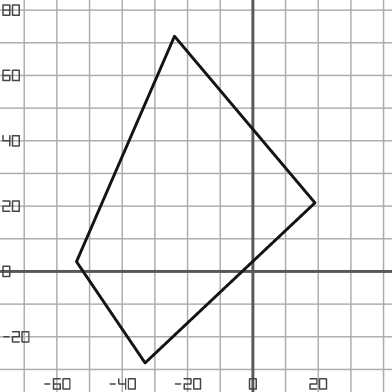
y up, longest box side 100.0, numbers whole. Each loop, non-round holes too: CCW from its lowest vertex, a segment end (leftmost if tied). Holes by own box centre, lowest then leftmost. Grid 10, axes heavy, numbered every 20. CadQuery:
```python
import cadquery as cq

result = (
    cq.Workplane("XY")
    .moveTo(-33.0, -28.0)
    .lineTo(19.0, 21.0)
    .lineTo(-24.0, 72.0)
    .lineTo(-54.0, 3.0)
    .close()
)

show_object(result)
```